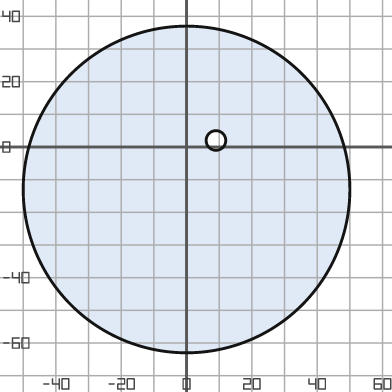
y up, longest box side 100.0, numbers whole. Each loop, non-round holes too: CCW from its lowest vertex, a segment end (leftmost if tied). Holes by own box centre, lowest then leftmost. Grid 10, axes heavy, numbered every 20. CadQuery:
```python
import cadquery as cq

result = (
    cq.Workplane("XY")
    .moveTo(0.0, -13.0)
    .circle(50.0)
    .moveTo(9.0, 2.0)
    .circle(3.0)
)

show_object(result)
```